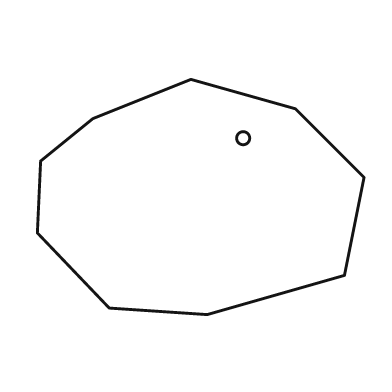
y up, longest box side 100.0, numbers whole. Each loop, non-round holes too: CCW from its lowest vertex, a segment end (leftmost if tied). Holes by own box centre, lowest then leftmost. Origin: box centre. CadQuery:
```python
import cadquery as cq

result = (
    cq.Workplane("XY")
    .moveTo(2.0, -36.0)
    .lineTo(44.0, -24.0)
    .lineTo(50.0, 6.0)
    .lineTo(29.0, 27.0)
    .lineTo(-3.0, 36.0)
    .lineTo(-33.0, 24.0)
    .lineTo(-49.0, 11.0)
    .lineTo(-50.0, -11.0)
    .lineTo(-28.0, -34.0)
    .close()
    .moveTo(13.0, 18.0)
    .circle(2.0)
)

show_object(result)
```